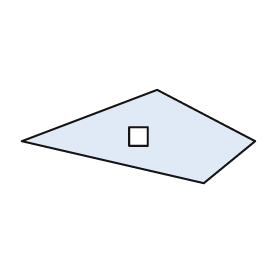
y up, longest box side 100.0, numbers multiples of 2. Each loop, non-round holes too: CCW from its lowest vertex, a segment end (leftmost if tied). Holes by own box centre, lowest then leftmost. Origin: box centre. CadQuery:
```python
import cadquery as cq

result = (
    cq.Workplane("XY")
    .moveTo(28.0, -20.0)
    .lineTo(50.0, -2.0)
    .lineTo(8.0, 20.0)
    .lineTo(-50.0, -2.0)
    .close()
    .moveTo(-4.0, -4.0)
    .lineTo(4.0, -4.0)
    .lineTo(4.0, 4.0)
    .lineTo(-4.0, 4.0)
    .close()
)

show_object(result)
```